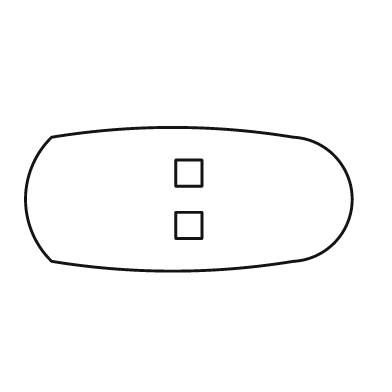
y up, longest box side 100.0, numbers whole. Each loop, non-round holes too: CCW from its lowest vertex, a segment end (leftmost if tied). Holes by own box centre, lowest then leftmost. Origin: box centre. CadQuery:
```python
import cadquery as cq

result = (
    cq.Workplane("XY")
    .moveTo(-42.0, -19.0)
    .threePointArc((-5.0, -22.0), (32.0, -19.0))
    .threePointArc((50.0, 0.0), (32.0, 19.0))
    .threePointArc((-5.0, 22.0), (-42.0, 19.0))
    .threePointArc((-50.0, 0.0), (-42.0, -19.0))
    .close()
    .moveTo(-4.0, -12.0)
    .lineTo(4.0, -12.0)
    .lineTo(4.0, -4.0)
    .lineTo(-4.0, -4.0)
    .close()
    .moveTo(-4.0, 4.0)
    .lineTo(4.0, 4.0)
    .lineTo(4.0, 12.0)
    .lineTo(-4.0, 12.0)
    .close()
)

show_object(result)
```